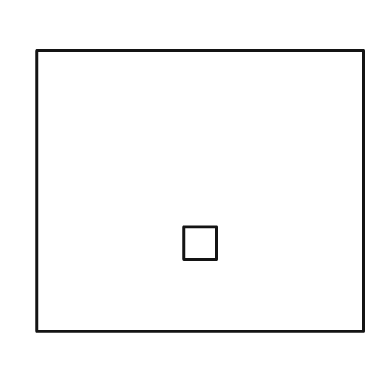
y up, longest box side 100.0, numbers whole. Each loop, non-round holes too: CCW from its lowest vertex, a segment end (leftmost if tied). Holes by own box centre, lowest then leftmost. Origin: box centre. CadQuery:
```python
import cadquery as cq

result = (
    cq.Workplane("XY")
    .moveTo(-50.0, -43.0)
    .lineTo(50.0, -43.0)
    .lineTo(50.0, 43.0)
    .lineTo(-50.0, 43.0)
    .close()
    .moveTo(-5.0, -21.0)
    .lineTo(5.0, -21.0)
    .lineTo(5.0, -11.0)
    .lineTo(-5.0, -11.0)
    .close()
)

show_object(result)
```